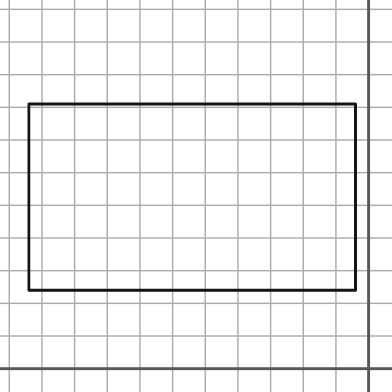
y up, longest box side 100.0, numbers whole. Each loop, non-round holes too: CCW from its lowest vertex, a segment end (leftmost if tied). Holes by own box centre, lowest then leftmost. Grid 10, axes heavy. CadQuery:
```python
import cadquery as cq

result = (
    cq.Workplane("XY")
    .moveTo(-104.0, 24.0)
    .lineTo(-4.0, 24.0)
    .lineTo(-4.0, 81.0)
    .lineTo(-104.0, 81.0)
    .close()
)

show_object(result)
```